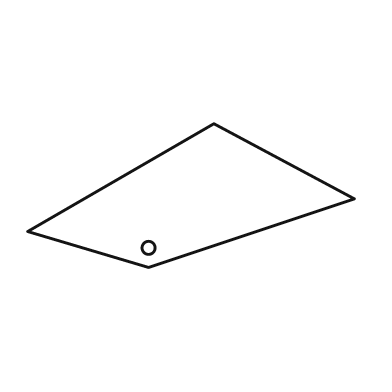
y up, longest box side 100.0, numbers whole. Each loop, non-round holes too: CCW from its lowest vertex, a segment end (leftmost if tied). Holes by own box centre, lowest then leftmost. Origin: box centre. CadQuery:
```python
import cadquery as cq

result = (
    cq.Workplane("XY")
    .moveTo(-13.0, -22.0)
    .lineTo(50.0, -1.0)
    .lineTo(7.0, 22.0)
    .lineTo(-50.0, -11.0)
    .close()
    .moveTo(-13.0, -16.0)
    .circle(2.0)
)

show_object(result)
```